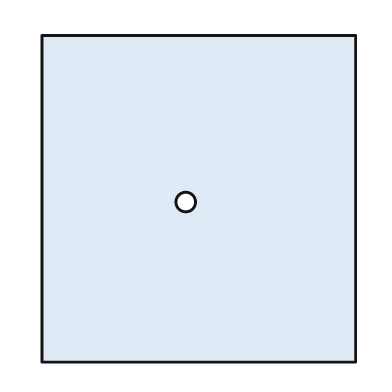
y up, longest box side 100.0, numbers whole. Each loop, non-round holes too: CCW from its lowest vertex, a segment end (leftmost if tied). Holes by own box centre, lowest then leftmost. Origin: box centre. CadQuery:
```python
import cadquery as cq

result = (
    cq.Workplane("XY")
    .moveTo(-48.0, -50.0)
    .lineTo(48.0, -50.0)
    .lineTo(48.0, 50.0)
    .lineTo(-48.0, 50.0)
    .close()
    .moveTo(-4.0, -1.0)
    .circle(3.0)
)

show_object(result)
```